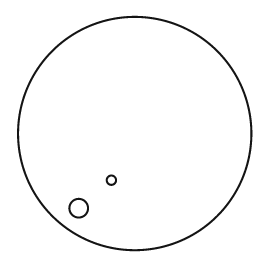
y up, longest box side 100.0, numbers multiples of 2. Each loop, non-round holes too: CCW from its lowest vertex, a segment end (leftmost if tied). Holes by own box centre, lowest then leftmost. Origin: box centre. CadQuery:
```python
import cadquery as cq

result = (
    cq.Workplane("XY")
    .moveTo(0.0, 0.0)
    .circle(50.0)
    .moveTo(-24.0, -32.0)
    .circle(4.0)
    .moveTo(-10.0, -20.0)
    .circle(2.0)
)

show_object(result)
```